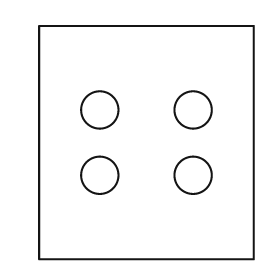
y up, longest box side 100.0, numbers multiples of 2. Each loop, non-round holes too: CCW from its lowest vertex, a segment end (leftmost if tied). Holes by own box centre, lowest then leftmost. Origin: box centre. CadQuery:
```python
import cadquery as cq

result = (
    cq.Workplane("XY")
    .moveTo(-46.0, -50.0)
    .lineTo(46.0, -50.0)
    .lineTo(46.0, 50.0)
    .lineTo(-46.0, 50.0)
    .close()
    .moveTo(-20.0, -14.0)
    .circle(8.0)
    .moveTo(20.0, -14.0)
    .circle(8.0)
    .moveTo(-20.0, 14.0)
    .circle(8.0)
    .moveTo(20.0, 14.0)
    .circle(8.0)
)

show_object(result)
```